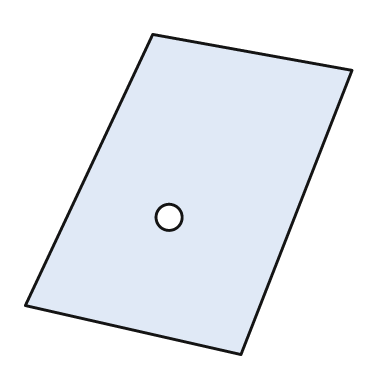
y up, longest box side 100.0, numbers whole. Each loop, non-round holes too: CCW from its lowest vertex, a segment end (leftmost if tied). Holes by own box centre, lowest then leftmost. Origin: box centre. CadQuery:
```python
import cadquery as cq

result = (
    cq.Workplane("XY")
    .moveTo(16.0, -49.0)
    .lineTo(50.0, 38.0)
    .lineTo(-11.0, 49.0)
    .lineTo(-50.0, -34.0)
    .close()
    .moveTo(-6.0, -7.0)
    .circle(4.0)
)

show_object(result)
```